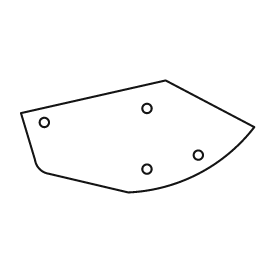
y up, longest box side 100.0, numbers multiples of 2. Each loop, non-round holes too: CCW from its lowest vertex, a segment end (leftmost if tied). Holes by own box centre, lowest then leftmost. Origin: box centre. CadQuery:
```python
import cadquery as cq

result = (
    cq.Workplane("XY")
    .moveTo(-4.0, -24.0)
    .threePointArc((26.0, -16.0), (50.0, 4.0))
    .lineTo(12.0, 24.0)
    .lineTo(-50.0, 10.0)
    .lineTo(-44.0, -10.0)
    .threePointArc((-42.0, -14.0), (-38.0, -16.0))
    .close()
    .moveTo(4.0, -14.0)
    .circle(2.0)
    .moveTo(26.0, -8.0)
    .circle(2.0)
    .moveTo(-40.0, 6.0)
    .circle(2.0)
    .moveTo(4.0, 12.0)
    .circle(2.0)
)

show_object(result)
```